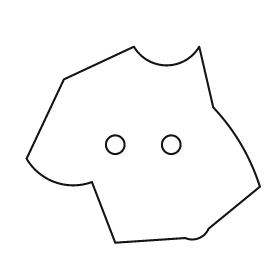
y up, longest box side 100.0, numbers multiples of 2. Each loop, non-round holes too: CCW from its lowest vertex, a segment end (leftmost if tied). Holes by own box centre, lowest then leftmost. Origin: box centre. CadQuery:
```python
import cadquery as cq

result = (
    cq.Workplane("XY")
    .moveTo(-12.0, -42.0)
    .lineTo(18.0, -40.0)
    .threePointArc((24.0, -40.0), (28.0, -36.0))
    .lineTo(50.0, -18.0)
    .threePointArc((42.0, 0.0), (30.0, 16.0))
    .lineTo(24.0, 42.0)
    .threePointArc((10.0, 34.0), (-4.0, 42.0))
    .lineTo(-34.0, 28.0)
    .lineTo(-50.0, -6.0)
    .threePointArc((-38.0, -16.0), (-22.0, -16.0))
    .close()
    .moveTo(-12.0, 0.0)
    .circle(4.0)
    .moveTo(12.0, 0.0)
    .circle(4.0)
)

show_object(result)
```